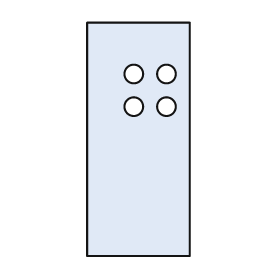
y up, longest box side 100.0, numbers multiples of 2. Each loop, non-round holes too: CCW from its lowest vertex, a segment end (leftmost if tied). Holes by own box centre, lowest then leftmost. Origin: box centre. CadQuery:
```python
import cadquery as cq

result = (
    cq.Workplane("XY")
    .moveTo(-22.0, -50.0)
    .lineTo(22.0, -50.0)
    .lineTo(22.0, 50.0)
    .lineTo(-22.0, 50.0)
    .close()
    .moveTo(-2.0, 14.0)
    .circle(4.0)
    .moveTo(12.0, 14.0)
    .circle(4.0)
    .moveTo(-2.0, 28.0)
    .circle(4.0)
    .moveTo(12.0, 28.0)
    .circle(4.0)
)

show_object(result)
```